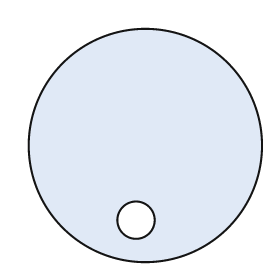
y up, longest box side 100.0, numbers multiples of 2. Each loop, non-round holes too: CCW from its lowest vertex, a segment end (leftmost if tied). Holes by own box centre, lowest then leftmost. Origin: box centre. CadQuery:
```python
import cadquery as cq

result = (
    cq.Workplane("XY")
    .moveTo(0.0, 0.0)
    .circle(50.0)
    .moveTo(-4.0, -32.0)
    .circle(8.0)
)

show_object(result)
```